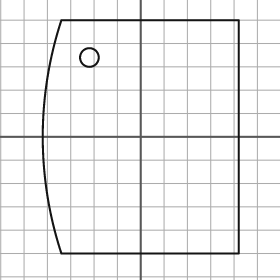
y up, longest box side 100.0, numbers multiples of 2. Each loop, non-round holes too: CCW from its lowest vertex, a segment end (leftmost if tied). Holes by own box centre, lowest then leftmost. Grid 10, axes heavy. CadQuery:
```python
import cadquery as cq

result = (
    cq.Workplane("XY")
    .moveTo(-34.0, -50.0)
    .lineTo(42.0, -50.0)
    .lineTo(42.0, 50.0)
    .lineTo(-34.0, 50.0)
    .threePointArc((-42.0, 0.0), (-34.0, -50.0))
    .close()
    .moveTo(-22.0, 34.0)
    .circle(4.0)
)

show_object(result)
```